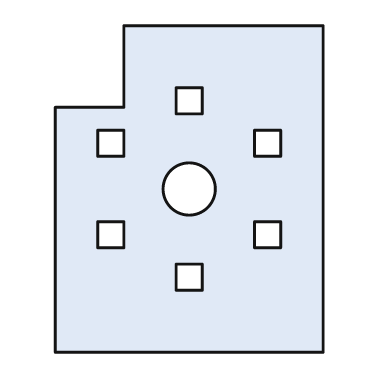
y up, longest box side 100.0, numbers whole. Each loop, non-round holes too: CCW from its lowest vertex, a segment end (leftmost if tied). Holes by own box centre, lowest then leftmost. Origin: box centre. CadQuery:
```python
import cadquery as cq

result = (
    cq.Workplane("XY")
    .moveTo(-41.0, -50.0)
    .lineTo(41.0, -50.0)
    .lineTo(41.0, 50.0)
    .lineTo(-20.0, 50.0)
    .lineTo(-20.0, 25.0)
    .lineTo(-41.0, 25.0)
    .close()
    .moveTo(-4.0, -31.0)
    .lineTo(4.0, -31.0)
    .lineTo(4.0, -23.0)
    .lineTo(-4.0, -23.0)
    .close()
    .moveTo(-28.0, -18.0)
    .lineTo(-20.0, -18.0)
    .lineTo(-20.0, -10.0)
    .lineTo(-28.0, -10.0)
    .close()
    .moveTo(20.0, -18.0)
    .lineTo(28.0, -18.0)
    .lineTo(28.0, -10.0)
    .lineTo(20.0, -10.0)
    .close()
    .moveTo(0.0, 0.0)
    .circle(8.0)
    .moveTo(-28.0, 10.0)
    .lineTo(-20.0, 10.0)
    .lineTo(-20.0, 18.0)
    .lineTo(-28.0, 18.0)
    .close()
    .moveTo(20.0, 10.0)
    .lineTo(28.0, 10.0)
    .lineTo(28.0, 18.0)
    .lineTo(20.0, 18.0)
    .close()
    .moveTo(-4.0, 23.0)
    .lineTo(4.0, 23.0)
    .lineTo(4.0, 31.0)
    .lineTo(-4.0, 31.0)
    .close()
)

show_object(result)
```